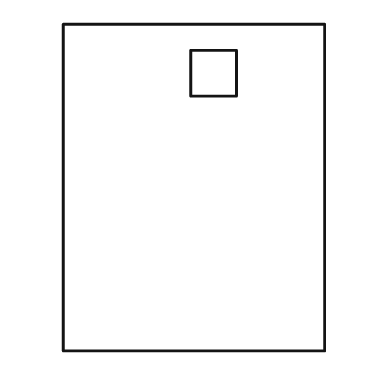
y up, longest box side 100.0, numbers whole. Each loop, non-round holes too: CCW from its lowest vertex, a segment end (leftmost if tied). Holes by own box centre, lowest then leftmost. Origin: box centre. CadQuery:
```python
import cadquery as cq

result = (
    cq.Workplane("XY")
    .moveTo(-40.0, -50.0)
    .lineTo(40.0, -50.0)
    .lineTo(40.0, 50.0)
    .lineTo(-40.0, 50.0)
    .close()
    .moveTo(-1.0, 28.0)
    .lineTo(13.0, 28.0)
    .lineTo(13.0, 42.0)
    .lineTo(-1.0, 42.0)
    .close()
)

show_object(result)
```